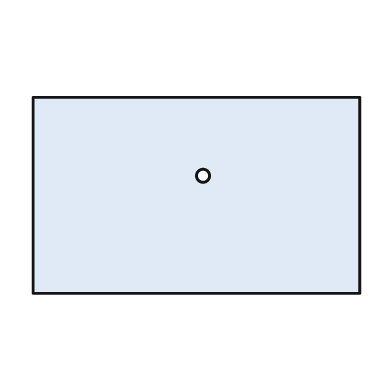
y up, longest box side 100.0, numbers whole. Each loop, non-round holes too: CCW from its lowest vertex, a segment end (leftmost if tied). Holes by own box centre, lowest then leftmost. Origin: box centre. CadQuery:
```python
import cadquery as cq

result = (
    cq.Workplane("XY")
    .moveTo(-50.0, -30.0)
    .lineTo(50.0, -30.0)
    .lineTo(50.0, 30.0)
    .lineTo(-50.0, 30.0)
    .close()
    .moveTo(2.0, 6.0)
    .circle(2.0)
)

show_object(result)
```